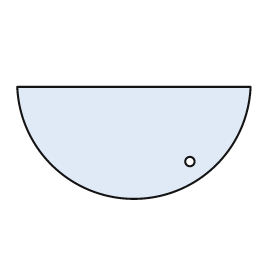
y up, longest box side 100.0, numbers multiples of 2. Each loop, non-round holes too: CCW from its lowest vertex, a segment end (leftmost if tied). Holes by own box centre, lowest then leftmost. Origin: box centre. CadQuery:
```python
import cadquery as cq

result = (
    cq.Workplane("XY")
    .moveTo(-50.0, 24.0)
    .threePointArc((0.0, -24.0), (50.0, 24.0))
    .close()
    .moveTo(24.0, -8.0)
    .circle(2.0)
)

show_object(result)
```